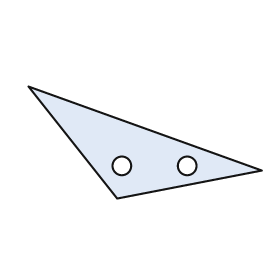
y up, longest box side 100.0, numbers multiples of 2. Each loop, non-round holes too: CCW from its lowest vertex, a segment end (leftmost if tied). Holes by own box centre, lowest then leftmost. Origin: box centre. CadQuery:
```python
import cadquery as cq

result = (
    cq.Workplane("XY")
    .moveTo(-12.0, -24.0)
    .lineTo(50.0, -12.0)
    .lineTo(-50.0, 24.0)
    .close()
    .moveTo(-10.0, -10.0)
    .circle(4.0)
    .moveTo(18.0, -10.0)
    .circle(4.0)
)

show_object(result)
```